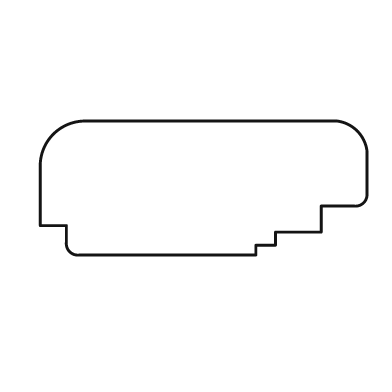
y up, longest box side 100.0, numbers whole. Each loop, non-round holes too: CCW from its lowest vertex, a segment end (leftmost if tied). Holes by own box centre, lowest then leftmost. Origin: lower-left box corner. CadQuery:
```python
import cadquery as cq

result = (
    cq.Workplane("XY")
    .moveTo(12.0, 0.0)
    .lineTo(66.0, 0.0)
    .lineTo(66.0, 3.0)
    .lineTo(72.0, 3.0)
    .lineTo(72.0, 7.0)
    .lineTo(86.0, 7.0)
    .lineTo(86.0, 15.0)
    .lineTo(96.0, 15.0)
    .threePointArc((99.0, 16.0), (100.0, 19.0))
    .lineTo(100.0, 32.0)
    .threePointArc((97.0, 38.0), (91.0, 41.0))
    .lineTo(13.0, 41.0)
    .threePointArc((4.0, 37.0), (0.0, 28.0))
    .lineTo(0.0, 9.0)
    .lineTo(8.0, 9.0)
    .lineTo(8.0, 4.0)
    .threePointArc((9.0, 1.0), (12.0, 0.0))
    .close()
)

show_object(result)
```